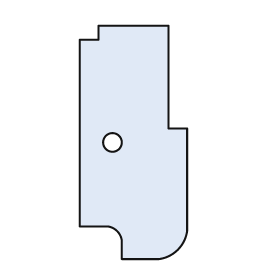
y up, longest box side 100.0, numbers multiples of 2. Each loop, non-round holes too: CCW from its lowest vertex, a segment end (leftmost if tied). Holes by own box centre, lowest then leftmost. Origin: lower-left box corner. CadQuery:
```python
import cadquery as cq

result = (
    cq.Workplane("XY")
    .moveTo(18.0, 0.0)
    .lineTo(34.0, 0.0)
    .threePointArc((42.0, 4.0), (46.0, 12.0))
    .lineTo(46.0, 56.0)
    .lineTo(38.0, 56.0)
    .lineTo(38.0, 100.0)
    .lineTo(8.0, 100.0)
    .lineTo(8.0, 94.0)
    .lineTo(0.0, 94.0)
    .lineTo(0.0, 14.0)
    .lineTo(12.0, 14.0)
    .threePointArc((16.0, 12.0), (18.0, 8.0))
    .close()
    .moveTo(14.0, 50.0)
    .circle(4.0)
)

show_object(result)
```